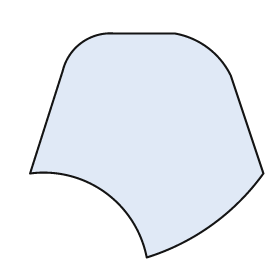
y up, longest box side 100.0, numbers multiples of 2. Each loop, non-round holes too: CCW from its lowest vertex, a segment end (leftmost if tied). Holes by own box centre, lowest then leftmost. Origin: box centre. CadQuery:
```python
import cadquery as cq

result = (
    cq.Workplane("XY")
    .moveTo(0.0, -48.0)
    .threePointArc((28.0, -34.0), (50.0, -12.0))
    .lineTo(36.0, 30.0)
    .threePointArc((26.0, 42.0), (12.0, 48.0))
    .lineTo(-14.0, 48.0)
    .threePointArc((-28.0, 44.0), (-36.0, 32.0))
    .lineTo(-50.0, -12.0)
    .threePointArc((-18.0, -20.0), (0.0, -48.0))
    .close()
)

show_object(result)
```